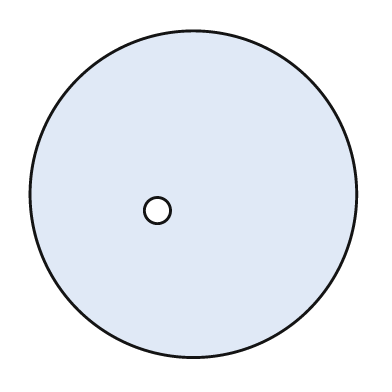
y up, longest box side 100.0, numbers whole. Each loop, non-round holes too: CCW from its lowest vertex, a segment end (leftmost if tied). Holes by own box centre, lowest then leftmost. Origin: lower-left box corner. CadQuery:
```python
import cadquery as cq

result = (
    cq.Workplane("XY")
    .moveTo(50.0, 50.0)
    .circle(50.0)
    .moveTo(39.0, 45.0)
    .circle(4.0)
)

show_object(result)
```